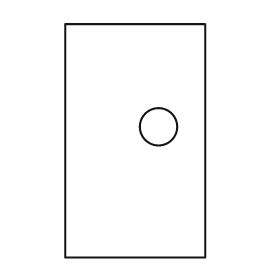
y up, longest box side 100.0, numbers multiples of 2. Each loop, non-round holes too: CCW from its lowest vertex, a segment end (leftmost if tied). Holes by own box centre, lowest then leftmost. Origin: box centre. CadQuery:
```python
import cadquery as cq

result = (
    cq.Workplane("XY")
    .moveTo(-30.0, -50.0)
    .lineTo(30.0, -50.0)
    .lineTo(30.0, 50.0)
    .lineTo(-30.0, 50.0)
    .close()
    .moveTo(10.0, 6.0)
    .circle(8.0)
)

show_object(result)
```